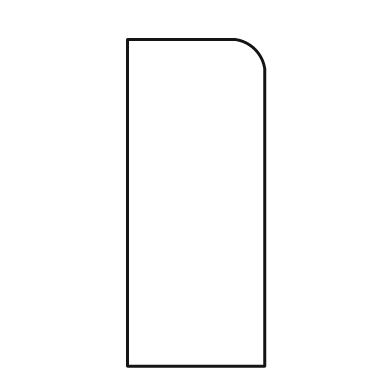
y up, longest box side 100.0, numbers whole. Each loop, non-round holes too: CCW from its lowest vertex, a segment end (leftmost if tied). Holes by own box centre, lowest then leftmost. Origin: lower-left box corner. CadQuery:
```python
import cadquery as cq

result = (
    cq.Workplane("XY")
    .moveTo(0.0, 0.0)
    .lineTo(42.0, 0.0)
    .lineTo(42.0, 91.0)
    .threePointArc((39.0, 97.0), (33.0, 100.0))
    .lineTo(0.0, 100.0)
    .close()
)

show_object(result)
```